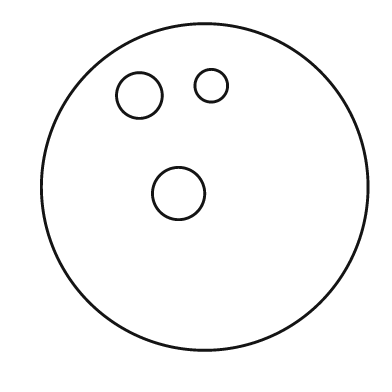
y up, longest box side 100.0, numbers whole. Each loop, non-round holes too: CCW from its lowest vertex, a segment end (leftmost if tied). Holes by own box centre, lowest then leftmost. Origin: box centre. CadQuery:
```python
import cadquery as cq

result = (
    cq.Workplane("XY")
    .moveTo(0.0, 0.0)
    .circle(50.0)
    .moveTo(-8.0, -2.0)
    .circle(8.0)
    .moveTo(-20.0, 28.0)
    .circle(7.0)
    .moveTo(2.0, 31.0)
    .circle(5.0)
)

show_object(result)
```